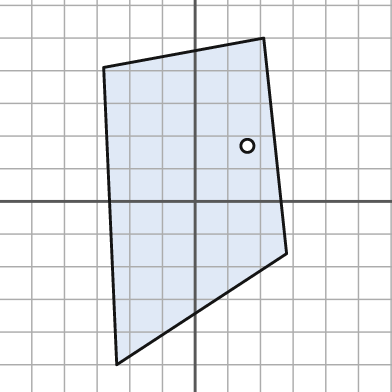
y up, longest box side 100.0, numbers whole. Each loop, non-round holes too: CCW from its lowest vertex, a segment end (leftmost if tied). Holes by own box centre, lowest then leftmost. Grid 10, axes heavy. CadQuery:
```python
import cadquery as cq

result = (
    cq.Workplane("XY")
    .moveTo(-24.0, -50.0)
    .lineTo(28.0, -16.0)
    .lineTo(21.0, 50.0)
    .lineTo(-28.0, 41.0)
    .close()
    .moveTo(16.0, 17.0)
    .circle(2.0)
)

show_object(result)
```